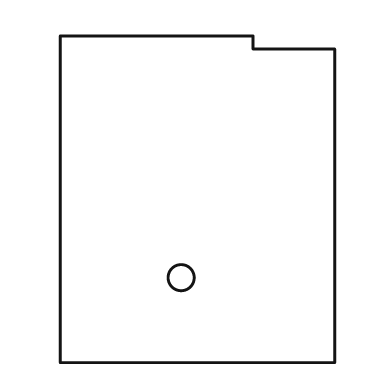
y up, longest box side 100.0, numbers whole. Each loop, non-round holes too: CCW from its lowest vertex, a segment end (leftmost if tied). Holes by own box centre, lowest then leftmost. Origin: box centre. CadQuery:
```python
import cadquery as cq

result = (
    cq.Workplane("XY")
    .moveTo(-42.0, -50.0)
    .lineTo(42.0, -50.0)
    .lineTo(42.0, 46.0)
    .lineTo(17.0, 46.0)
    .lineTo(17.0, 50.0)
    .lineTo(-42.0, 50.0)
    .close()
    .moveTo(-5.0, -24.0)
    .circle(4.0)
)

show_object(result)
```